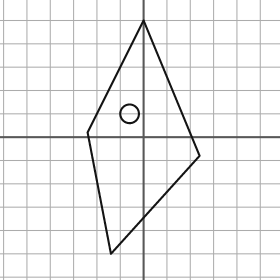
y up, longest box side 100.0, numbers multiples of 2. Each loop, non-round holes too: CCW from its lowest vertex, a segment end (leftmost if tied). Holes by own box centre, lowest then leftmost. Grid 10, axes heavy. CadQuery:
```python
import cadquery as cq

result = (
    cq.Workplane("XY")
    .moveTo(-14.0, -50.0)
    .lineTo(24.0, -8.0)
    .lineTo(0.0, 50.0)
    .lineTo(-24.0, 2.0)
    .close()
    .moveTo(-6.0, 10.0)
    .circle(4.0)
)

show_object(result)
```